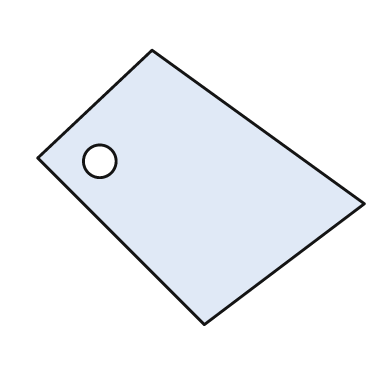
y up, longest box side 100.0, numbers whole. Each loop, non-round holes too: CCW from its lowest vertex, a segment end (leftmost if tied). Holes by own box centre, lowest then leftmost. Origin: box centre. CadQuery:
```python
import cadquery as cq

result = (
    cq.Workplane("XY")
    .moveTo(1.0, -42.0)
    .lineTo(50.0, -5.0)
    .lineTo(-15.0, 42.0)
    .lineTo(-50.0, 9.0)
    .close()
    .moveTo(-31.0, 8.0)
    .circle(5.0)
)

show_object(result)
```